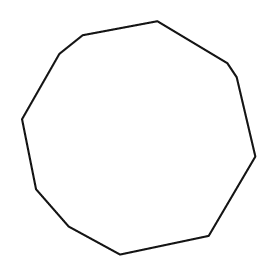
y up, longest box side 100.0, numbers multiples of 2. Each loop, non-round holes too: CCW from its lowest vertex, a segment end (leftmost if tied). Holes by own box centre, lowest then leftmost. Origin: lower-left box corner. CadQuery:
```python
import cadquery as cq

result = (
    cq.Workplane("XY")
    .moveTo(42.0, 0.0)
    .lineTo(80.0, 8.0)
    .lineTo(100.0, 42.0)
    .lineTo(92.0, 76.0)
    .lineTo(88.0, 82.0)
    .lineTo(58.0, 100.0)
    .lineTo(26.0, 94.0)
    .lineTo(16.0, 86.0)
    .lineTo(0.0, 58.0)
    .lineTo(6.0, 28.0)
    .lineTo(20.0, 12.0)
    .close()
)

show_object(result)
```